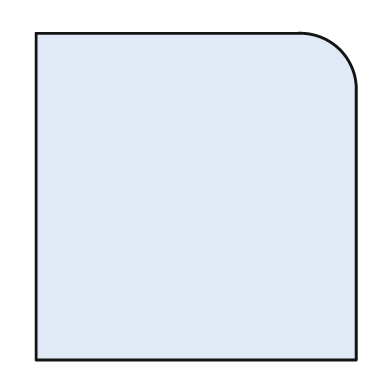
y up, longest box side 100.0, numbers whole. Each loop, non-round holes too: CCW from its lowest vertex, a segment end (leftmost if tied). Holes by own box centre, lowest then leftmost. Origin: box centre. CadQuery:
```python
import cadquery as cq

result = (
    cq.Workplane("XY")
    .moveTo(-49.0, -50.0)
    .lineTo(49.0, -50.0)
    .lineTo(49.0, 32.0)
    .threePointArc((44.0, 45.0), (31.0, 50.0))
    .lineTo(-49.0, 50.0)
    .close()
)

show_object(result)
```